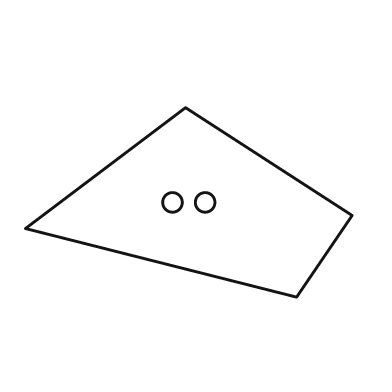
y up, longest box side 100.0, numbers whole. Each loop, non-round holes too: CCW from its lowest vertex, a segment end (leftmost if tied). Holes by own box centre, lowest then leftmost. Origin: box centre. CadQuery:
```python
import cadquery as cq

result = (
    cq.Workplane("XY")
    .moveTo(33.0, -29.0)
    .lineTo(50.0, -4.0)
    .lineTo(-1.0, 29.0)
    .lineTo(-50.0, -8.0)
    .close()
    .moveTo(-5.0, 0.0)
    .circle(3.0)
    .moveTo(5.0, 0.0)
    .circle(3.0)
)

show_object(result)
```